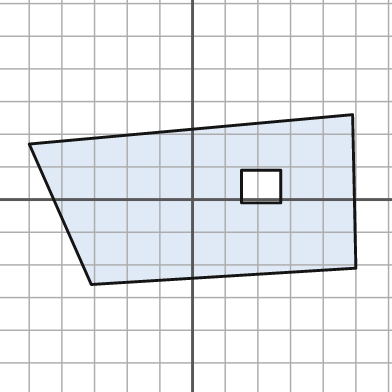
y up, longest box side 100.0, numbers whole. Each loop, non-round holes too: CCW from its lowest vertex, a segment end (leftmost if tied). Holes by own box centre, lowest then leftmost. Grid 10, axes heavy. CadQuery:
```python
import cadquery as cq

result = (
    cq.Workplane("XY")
    .moveTo(-31.0, -26.0)
    .lineTo(50.0, -21.0)
    .lineTo(49.0, 26.0)
    .lineTo(-50.0, 17.0)
    .close()
    .moveTo(15.0, -1.0)
    .lineTo(27.0, -1.0)
    .lineTo(27.0, 9.0)
    .lineTo(15.0, 9.0)
    .close()
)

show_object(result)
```